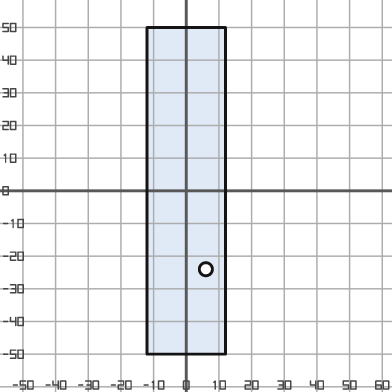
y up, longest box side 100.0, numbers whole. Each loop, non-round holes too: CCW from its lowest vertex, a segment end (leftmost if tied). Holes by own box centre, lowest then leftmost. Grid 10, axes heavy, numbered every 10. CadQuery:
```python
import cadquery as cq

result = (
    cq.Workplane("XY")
    .moveTo(-12.0, -50.0)
    .lineTo(12.0, -50.0)
    .lineTo(12.0, 50.0)
    .lineTo(-12.0, 50.0)
    .close()
    .moveTo(6.0, -24.0)
    .circle(2.0)
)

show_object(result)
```